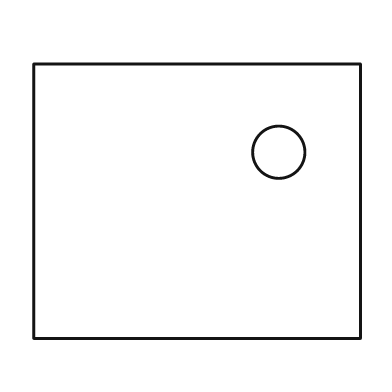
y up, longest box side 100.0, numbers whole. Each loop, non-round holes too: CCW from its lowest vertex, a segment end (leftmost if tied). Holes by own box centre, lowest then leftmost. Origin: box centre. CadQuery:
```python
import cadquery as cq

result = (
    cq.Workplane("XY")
    .moveTo(-50.0, -42.0)
    .lineTo(50.0, -42.0)
    .lineTo(50.0, 42.0)
    .lineTo(-50.0, 42.0)
    .close()
    .moveTo(25.0, 15.0)
    .circle(8.0)
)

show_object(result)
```